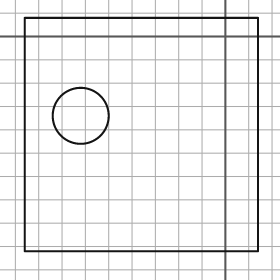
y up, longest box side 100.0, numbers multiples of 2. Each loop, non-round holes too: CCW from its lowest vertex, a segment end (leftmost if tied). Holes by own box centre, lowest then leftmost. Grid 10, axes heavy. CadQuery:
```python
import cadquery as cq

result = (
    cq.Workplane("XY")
    .moveTo(-86.0, -92.0)
    .lineTo(14.0, -92.0)
    .lineTo(14.0, 8.0)
    .lineTo(-86.0, 8.0)
    .close()
    .moveTo(-62.0, -34.0)
    .circle(12.0)
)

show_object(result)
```